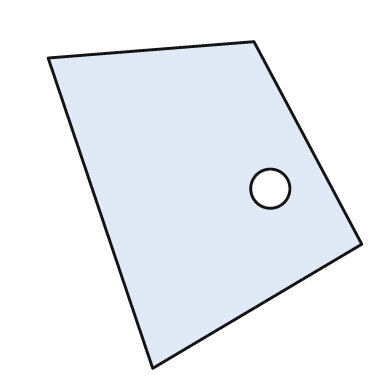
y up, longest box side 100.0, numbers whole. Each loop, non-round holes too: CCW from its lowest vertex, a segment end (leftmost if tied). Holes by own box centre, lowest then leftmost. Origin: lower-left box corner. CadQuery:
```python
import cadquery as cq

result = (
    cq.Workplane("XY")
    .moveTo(32.0, 0.0)
    .lineTo(96.0, 38.0)
    .lineTo(63.0, 100.0)
    .lineTo(0.0, 95.0)
    .close()
    .moveTo(68.0, 55.0)
    .circle(6.0)
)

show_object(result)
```